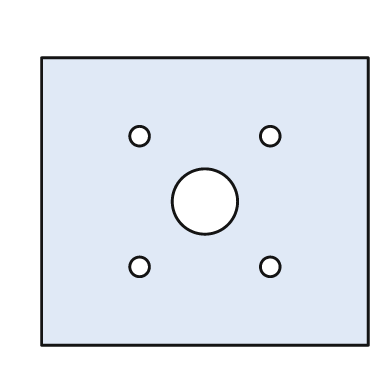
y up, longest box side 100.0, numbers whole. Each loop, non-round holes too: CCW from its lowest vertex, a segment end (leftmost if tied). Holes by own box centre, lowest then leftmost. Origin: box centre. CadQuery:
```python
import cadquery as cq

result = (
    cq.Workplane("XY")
    .moveTo(-50.0, -44.0)
    .lineTo(50.0, -44.0)
    .lineTo(50.0, 44.0)
    .lineTo(-50.0, 44.0)
    .close()
    .moveTo(-20.0, -20.0)
    .circle(3.0)
    .moveTo(20.0, -20.0)
    .circle(3.0)
    .moveTo(0.0, 0.0)
    .circle(10.0)
    .moveTo(-20.0, 20.0)
    .circle(3.0)
    .moveTo(20.0, 20.0)
    .circle(3.0)
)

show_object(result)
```